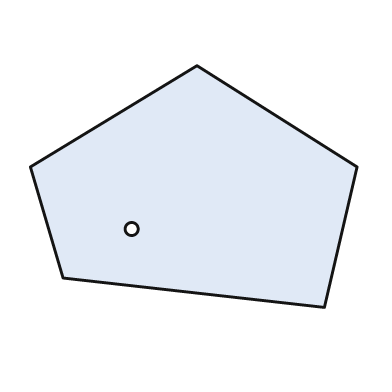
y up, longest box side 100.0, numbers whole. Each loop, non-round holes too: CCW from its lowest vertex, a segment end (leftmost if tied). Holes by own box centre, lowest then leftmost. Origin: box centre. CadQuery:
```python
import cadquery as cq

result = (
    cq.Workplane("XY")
    .moveTo(40.0, -37.0)
    .lineTo(50.0, 6.0)
    .lineTo(1.0, 37.0)
    .lineTo(-50.0, 6.0)
    .lineTo(-40.0, -28.0)
    .close()
    .moveTo(-19.0, -13.0)
    .circle(2.0)
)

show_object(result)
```